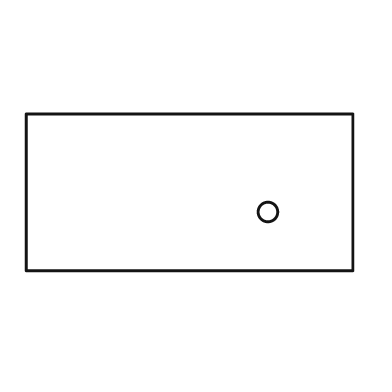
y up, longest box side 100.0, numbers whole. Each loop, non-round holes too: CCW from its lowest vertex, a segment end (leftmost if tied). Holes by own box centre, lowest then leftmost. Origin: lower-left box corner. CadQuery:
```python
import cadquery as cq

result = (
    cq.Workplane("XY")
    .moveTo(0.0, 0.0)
    .lineTo(100.0, 0.0)
    .lineTo(100.0, 48.0)
    .lineTo(0.0, 48.0)
    .close()
    .moveTo(74.0, 18.0)
    .circle(3.0)
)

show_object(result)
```